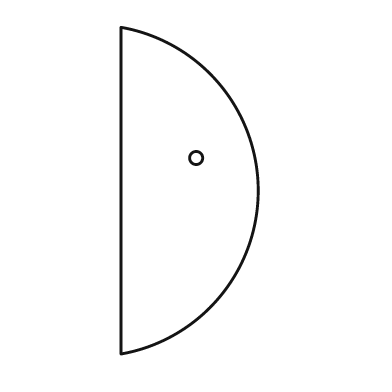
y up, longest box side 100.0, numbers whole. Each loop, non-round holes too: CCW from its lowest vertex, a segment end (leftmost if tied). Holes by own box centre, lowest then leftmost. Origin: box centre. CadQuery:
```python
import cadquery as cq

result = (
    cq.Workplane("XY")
    .moveTo(-21.0, -50.0)
    .threePointArc((21.0, 0.0), (-21.0, 50.0))
    .close()
    .moveTo(2.0, 10.0)
    .circle(2.0)
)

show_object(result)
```